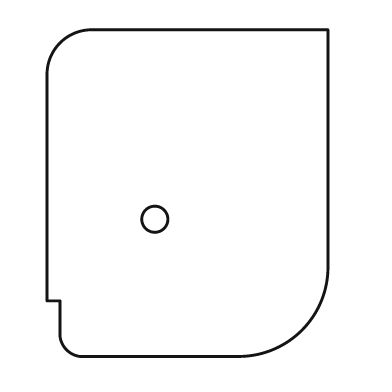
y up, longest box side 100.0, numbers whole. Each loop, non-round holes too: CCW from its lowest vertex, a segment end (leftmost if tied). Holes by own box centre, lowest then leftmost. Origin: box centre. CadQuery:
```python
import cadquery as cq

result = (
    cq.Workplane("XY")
    .moveTo(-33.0, -50.0)
    .lineTo(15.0, -50.0)
    .threePointArc((35.0, -42.0), (43.0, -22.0))
    .lineTo(43.0, 50.0)
    .lineTo(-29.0, 50.0)
    .threePointArc((-39.0, 46.0), (-43.0, 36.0))
    .lineTo(-43.0, -33.0)
    .lineTo(-39.0, -33.0)
    .lineTo(-39.0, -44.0)
    .threePointArc((-37.0, -48.0), (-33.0, -50.0))
    .close()
    .moveTo(-10.0, -8.0)
    .circle(4.0)
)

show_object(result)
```